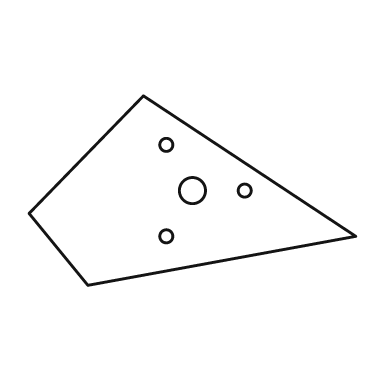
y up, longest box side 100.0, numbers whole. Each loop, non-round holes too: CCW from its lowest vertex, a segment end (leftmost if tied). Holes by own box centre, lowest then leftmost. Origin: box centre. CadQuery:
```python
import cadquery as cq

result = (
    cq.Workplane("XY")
    .moveTo(-32.0, -29.0)
    .lineTo(50.0, -14.0)
    .lineTo(-15.0, 29.0)
    .lineTo(-50.0, -7.0)
    .close()
    .moveTo(-8.0, -14.0)
    .circle(2.0)
    .moveTo(0.0, 0.0)
    .circle(4.0)
    .moveTo(16.0, 0.0)
    .circle(2.0)
    .moveTo(-8.0, 14.0)
    .circle(2.0)
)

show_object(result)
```